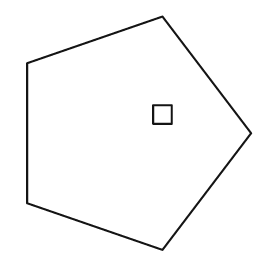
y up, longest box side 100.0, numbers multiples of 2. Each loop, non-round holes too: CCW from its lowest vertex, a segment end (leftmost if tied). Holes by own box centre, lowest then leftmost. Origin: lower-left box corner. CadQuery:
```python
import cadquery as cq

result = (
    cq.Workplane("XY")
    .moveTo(58.0, 0.0)
    .lineTo(96.0, 50.0)
    .lineTo(58.0, 100.0)
    .lineTo(0.0, 80.0)
    .lineTo(0.0, 20.0)
    .close()
    .moveTo(54.0, 54.0)
    .lineTo(62.0, 54.0)
    .lineTo(62.0, 62.0)
    .lineTo(54.0, 62.0)
    .close()
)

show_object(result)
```